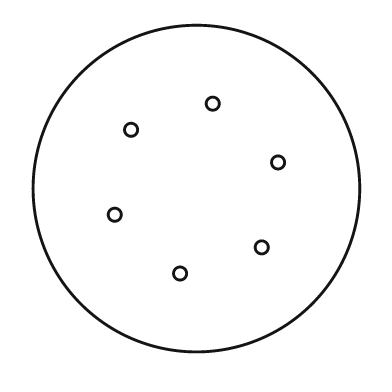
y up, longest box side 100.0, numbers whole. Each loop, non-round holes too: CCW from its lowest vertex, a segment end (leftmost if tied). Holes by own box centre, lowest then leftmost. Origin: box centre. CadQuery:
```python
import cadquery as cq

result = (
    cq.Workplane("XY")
    .moveTo(0.0, 0.0)
    .circle(50.0)
    .moveTo(-5.0, -26.0)
    .circle(2.0)
    .moveTo(20.0, -18.0)
    .circle(2.0)
    .moveTo(-25.0, -8.0)
    .circle(2.0)
    .moveTo(25.0, 8.0)
    .circle(2.0)
    .moveTo(-20.0, 18.0)
    .circle(2.0)
    .moveTo(5.0, 26.0)
    .circle(2.0)
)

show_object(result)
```